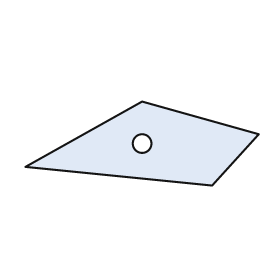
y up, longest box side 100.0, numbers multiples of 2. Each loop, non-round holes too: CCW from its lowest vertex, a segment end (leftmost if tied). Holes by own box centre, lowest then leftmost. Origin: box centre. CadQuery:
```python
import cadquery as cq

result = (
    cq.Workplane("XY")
    .moveTo(30.0, -18.0)
    .lineTo(50.0, 4.0)
    .lineTo(0.0, 18.0)
    .lineTo(-50.0, -10.0)
    .close()
    .moveTo(0.0, 0.0)
    .circle(4.0)
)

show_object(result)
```